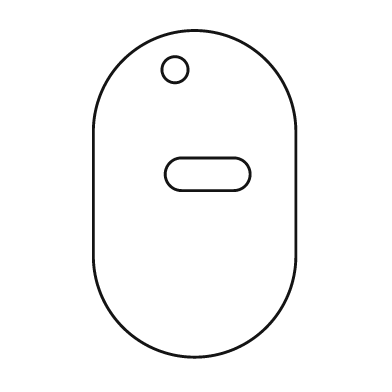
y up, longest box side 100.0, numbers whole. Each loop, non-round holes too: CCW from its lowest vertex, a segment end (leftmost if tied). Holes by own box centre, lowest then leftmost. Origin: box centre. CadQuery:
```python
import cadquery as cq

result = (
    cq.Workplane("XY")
    .moveTo(-31.0, -19.0)
    .threePointArc((0.0, -50.0), (31.0, -19.0))
    .lineTo(31.0, 19.0)
    .threePointArc((0.0, 50.0), (-31.0, 19.0))
    .close()
    .moveTo(-4.0, 1.0)
    .lineTo(12.0, 1.0)
    .threePointArc((17.0, 6.0), (12.0, 11.0))
    .lineTo(-4.0, 11.0)
    .threePointArc((-9.0, 6.0), (-4.0, 1.0))
    .close()
    .moveTo(-6.0, 38.0)
    .circle(4.0)
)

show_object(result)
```